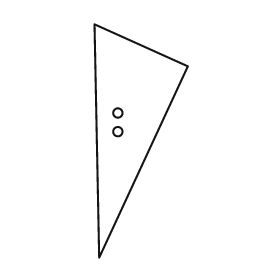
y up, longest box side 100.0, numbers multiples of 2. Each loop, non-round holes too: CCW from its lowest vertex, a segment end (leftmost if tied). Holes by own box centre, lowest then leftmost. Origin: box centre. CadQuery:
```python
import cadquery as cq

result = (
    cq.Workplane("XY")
    .moveTo(-18.0, -50.0)
    .lineTo(20.0, 32.0)
    .lineTo(-20.0, 50.0)
    .close()
    .moveTo(-10.0, 4.0)
    .circle(2.0)
    .moveTo(-10.0, 12.0)
    .circle(2.0)
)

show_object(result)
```